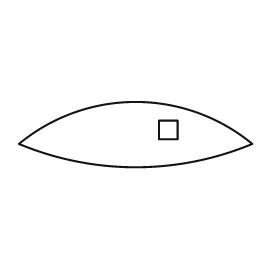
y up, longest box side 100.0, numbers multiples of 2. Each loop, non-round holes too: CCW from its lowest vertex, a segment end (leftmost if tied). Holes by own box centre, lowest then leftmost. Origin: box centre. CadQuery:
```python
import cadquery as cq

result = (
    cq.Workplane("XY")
    .moveTo(-50.0, -4.0)
    .threePointArc((0.0, -14.0), (50.0, -4.0))
    .threePointArc((0.0, 14.0), (-50.0, -4.0))
    .close()
    .moveTo(10.0, -2.0)
    .lineTo(18.0, -2.0)
    .lineTo(18.0, 6.0)
    .lineTo(10.0, 6.0)
    .close()
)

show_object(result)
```